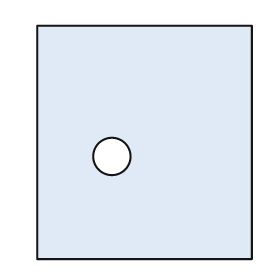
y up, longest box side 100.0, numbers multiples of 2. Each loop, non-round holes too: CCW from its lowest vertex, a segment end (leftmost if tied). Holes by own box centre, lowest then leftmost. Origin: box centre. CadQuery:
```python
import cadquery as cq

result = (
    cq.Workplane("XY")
    .moveTo(-46.0, -50.0)
    .lineTo(46.0, -50.0)
    .lineTo(46.0, 50.0)
    .lineTo(-46.0, 50.0)
    .close()
    .moveTo(-14.0, -6.0)
    .circle(8.0)
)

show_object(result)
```